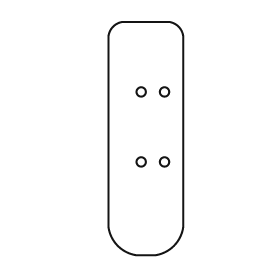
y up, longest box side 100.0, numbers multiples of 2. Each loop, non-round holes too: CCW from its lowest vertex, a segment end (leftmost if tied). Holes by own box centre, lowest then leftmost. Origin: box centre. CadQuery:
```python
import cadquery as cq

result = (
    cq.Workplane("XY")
    .moveTo(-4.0, -50.0)
    .lineTo(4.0, -50.0)
    .threePointArc((12.0, -46.0), (16.0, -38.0))
    .lineTo(16.0, 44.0)
    .threePointArc((14.0, 48.0), (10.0, 50.0))
    .lineTo(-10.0, 50.0)
    .threePointArc((-14.0, 48.0), (-16.0, 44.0))
    .lineTo(-16.0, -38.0)
    .threePointArc((-12.0, -46.0), (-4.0, -50.0))
    .close()
    .moveTo(-2.0, -10.0)
    .circle(2.0)
    .moveTo(8.0, -10.0)
    .circle(2.0)
    .moveTo(-2.0, 20.0)
    .circle(2.0)
    .moveTo(8.0, 20.0)
    .circle(2.0)
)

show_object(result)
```